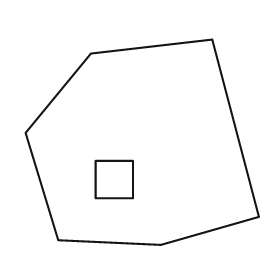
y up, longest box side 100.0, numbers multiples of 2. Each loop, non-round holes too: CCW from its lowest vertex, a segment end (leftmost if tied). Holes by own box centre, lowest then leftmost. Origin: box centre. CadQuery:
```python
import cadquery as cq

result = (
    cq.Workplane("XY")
    .moveTo(8.0, -44.0)
    .lineTo(50.0, -32.0)
    .lineTo(30.0, 44.0)
    .lineTo(-22.0, 38.0)
    .lineTo(-50.0, 4.0)
    .lineTo(-36.0, -42.0)
    .close()
    .moveTo(-20.0, -24.0)
    .lineTo(-4.0, -24.0)
    .lineTo(-4.0, -8.0)
    .lineTo(-20.0, -8.0)
    .close()
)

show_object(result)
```